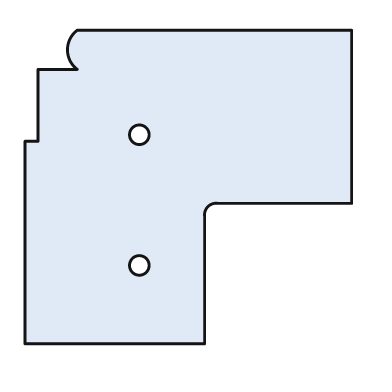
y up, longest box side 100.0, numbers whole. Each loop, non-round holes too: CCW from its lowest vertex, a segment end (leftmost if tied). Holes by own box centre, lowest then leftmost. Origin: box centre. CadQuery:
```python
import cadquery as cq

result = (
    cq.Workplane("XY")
    .moveTo(-50.0, -48.0)
    .lineTo(5.0, -48.0)
    .lineTo(5.0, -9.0)
    .threePointArc((6.0, -6.0), (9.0, -5.0))
    .lineTo(50.0, -5.0)
    .lineTo(50.0, 48.0)
    .lineTo(-34.0, 48.0)
    .threePointArc((-37.0, 42.0), (-34.0, 36.0))
    .lineTo(-46.0, 36.0)
    .lineTo(-46.0, 14.0)
    .lineTo(-50.0, 14.0)
    .close()
    .moveTo(-15.0, -24.0)
    .circle(3.0)
    .moveTo(-15.0, 16.0)
    .circle(3.0)
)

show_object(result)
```